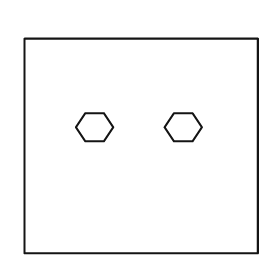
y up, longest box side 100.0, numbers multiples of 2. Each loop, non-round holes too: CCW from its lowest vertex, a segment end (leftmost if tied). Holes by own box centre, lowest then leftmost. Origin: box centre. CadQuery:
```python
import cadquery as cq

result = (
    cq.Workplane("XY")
    .moveTo(-50.0, -46.0)
    .lineTo(50.0, -46.0)
    .lineTo(50.0, 46.0)
    .lineTo(-50.0, 46.0)
    .close()
    .moveTo(-24.0, 2.0)
    .lineTo(-16.0, 2.0)
    .lineTo(-12.0, 8.0)
    .lineTo(-16.0, 14.0)
    .lineTo(-24.0, 14.0)
    .lineTo(-28.0, 8.0)
    .close()
    .moveTo(14.0, 2.0)
    .lineTo(22.0, 2.0)
    .lineTo(26.0, 8.0)
    .lineTo(22.0, 14.0)
    .lineTo(14.0, 14.0)
    .lineTo(10.0, 8.0)
    .close()
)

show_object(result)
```